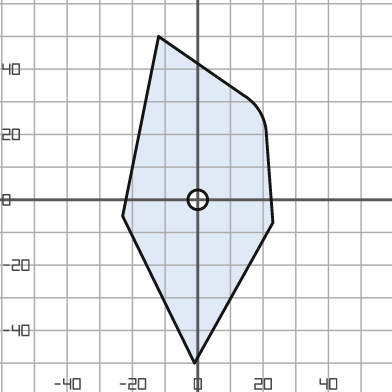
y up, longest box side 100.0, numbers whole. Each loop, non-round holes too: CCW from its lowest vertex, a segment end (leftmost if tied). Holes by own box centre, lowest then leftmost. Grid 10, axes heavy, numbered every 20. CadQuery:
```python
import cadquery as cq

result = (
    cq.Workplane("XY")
    .moveTo(-1.0, -50.0)
    .lineTo(23.0, -7.0)
    .lineTo(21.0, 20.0)
    .threePointArc((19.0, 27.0), (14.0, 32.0))
    .lineTo(-12.0, 50.0)
    .lineTo(-23.0, -5.0)
    .close()
    .moveTo(0.0, 0.0)
    .circle(3.0)
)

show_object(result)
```